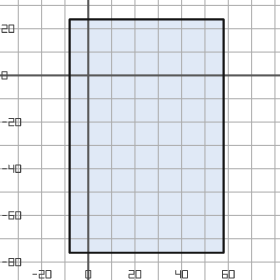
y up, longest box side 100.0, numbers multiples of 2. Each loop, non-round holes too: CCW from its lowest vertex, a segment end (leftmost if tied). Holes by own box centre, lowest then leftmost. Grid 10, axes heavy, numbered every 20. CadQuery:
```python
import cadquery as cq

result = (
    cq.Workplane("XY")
    .moveTo(-8.0, -76.0)
    .lineTo(58.0, -76.0)
    .lineTo(58.0, 24.0)
    .lineTo(-8.0, 24.0)
    .close()
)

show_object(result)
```